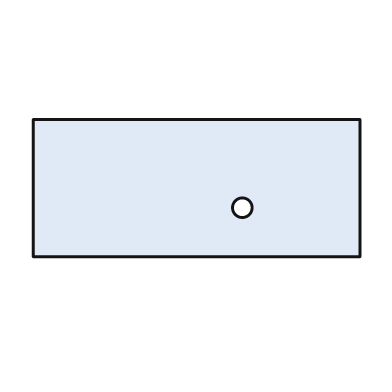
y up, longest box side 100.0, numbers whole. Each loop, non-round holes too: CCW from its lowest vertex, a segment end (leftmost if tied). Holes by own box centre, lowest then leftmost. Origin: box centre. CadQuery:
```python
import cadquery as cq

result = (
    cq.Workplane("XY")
    .moveTo(-50.0, -21.0)
    .lineTo(50.0, -21.0)
    .lineTo(50.0, 21.0)
    .lineTo(-50.0, 21.0)
    .close()
    .moveTo(14.0, -6.0)
    .circle(3.0)
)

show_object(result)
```